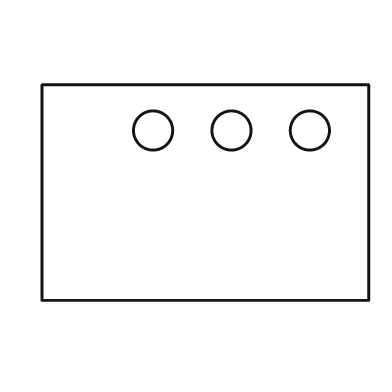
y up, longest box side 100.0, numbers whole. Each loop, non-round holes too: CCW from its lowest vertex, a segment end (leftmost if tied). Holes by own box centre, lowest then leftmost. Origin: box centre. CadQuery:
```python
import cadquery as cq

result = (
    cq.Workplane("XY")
    .moveTo(-50.0, -33.0)
    .lineTo(50.0, -33.0)
    .lineTo(50.0, 33.0)
    .lineTo(-50.0, 33.0)
    .close()
    .moveTo(-16.0, 19.0)
    .circle(6.0)
    .moveTo(8.0, 19.0)
    .circle(6.0)
    .moveTo(32.0, 19.0)
    .circle(6.0)
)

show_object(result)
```